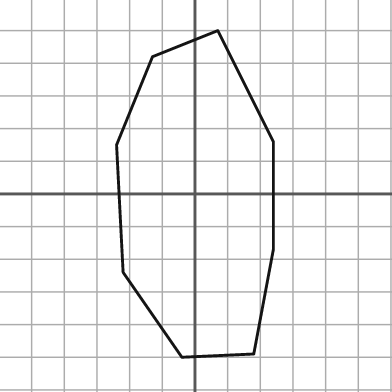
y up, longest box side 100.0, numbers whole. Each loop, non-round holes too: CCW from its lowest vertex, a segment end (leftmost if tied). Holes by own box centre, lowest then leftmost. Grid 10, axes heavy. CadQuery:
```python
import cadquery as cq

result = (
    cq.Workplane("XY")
    .moveTo(-4.0, -50.0)
    .lineTo(18.0, -49.0)
    .lineTo(24.0, -17.0)
    .lineTo(24.0, 16.0)
    .lineTo(7.0, 50.0)
    .lineTo(-13.0, 42.0)
    .lineTo(-24.0, 15.0)
    .lineTo(-22.0, -24.0)
    .close()
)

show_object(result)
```